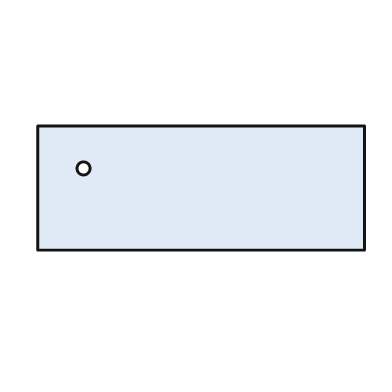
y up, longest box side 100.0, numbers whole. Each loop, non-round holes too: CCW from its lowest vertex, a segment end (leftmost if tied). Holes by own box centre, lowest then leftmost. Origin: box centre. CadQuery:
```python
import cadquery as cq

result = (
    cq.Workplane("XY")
    .moveTo(-50.0, -19.0)
    .lineTo(50.0, -19.0)
    .lineTo(50.0, 19.0)
    .lineTo(-50.0, 19.0)
    .close()
    .moveTo(-36.0, 6.0)
    .circle(2.0)
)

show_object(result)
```